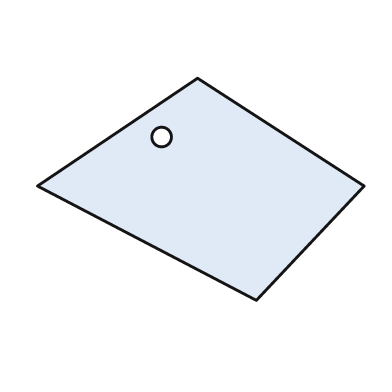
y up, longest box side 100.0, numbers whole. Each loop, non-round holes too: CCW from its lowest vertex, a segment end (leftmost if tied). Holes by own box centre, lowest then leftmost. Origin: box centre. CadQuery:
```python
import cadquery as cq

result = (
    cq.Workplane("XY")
    .moveTo(17.0, -34.0)
    .lineTo(50.0, 1.0)
    .lineTo(-1.0, 34.0)
    .lineTo(-50.0, 1.0)
    .close()
    .moveTo(-12.0, 16.0)
    .circle(3.0)
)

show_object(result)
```